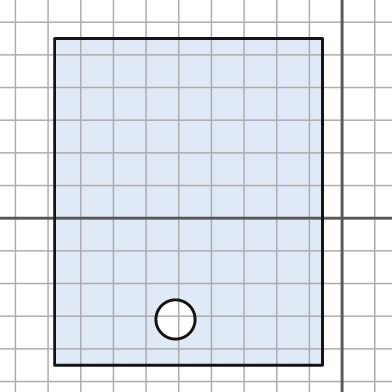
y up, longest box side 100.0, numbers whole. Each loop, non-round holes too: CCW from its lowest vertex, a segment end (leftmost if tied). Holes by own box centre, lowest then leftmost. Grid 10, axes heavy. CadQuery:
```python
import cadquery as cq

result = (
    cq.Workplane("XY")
    .moveTo(-88.0, -45.0)
    .lineTo(-6.0, -45.0)
    .lineTo(-6.0, 55.0)
    .lineTo(-88.0, 55.0)
    .close()
    .moveTo(-51.0, -31.0)
    .circle(6.0)
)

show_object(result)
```